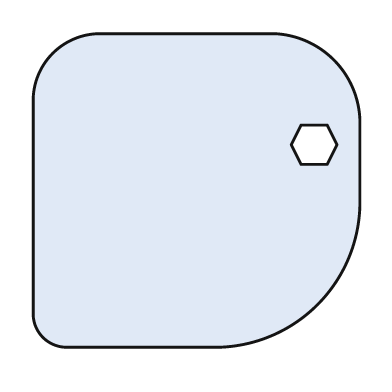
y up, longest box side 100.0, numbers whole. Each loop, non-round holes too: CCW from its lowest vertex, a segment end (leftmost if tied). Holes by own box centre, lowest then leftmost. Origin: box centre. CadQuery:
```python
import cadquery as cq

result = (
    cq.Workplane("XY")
    .moveTo(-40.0, -48.0)
    .lineTo(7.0, -48.0)
    .threePointArc((37.0, -35.0), (50.0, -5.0))
    .lineTo(50.0, 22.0)
    .threePointArc((42.0, 40.0), (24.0, 48.0))
    .lineTo(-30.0, 48.0)
    .threePointArc((-44.0, 42.0), (-50.0, 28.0))
    .lineTo(-50.0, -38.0)
    .threePointArc((-47.0, -45.0), (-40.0, -48.0))
    .close()
    .moveTo(32.0, 8.0)
    .lineTo(40.0, 8.0)
    .lineTo(43.0, 14.0)
    .lineTo(40.0, 20.0)
    .lineTo(32.0, 20.0)
    .lineTo(29.0, 14.0)
    .close()
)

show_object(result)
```